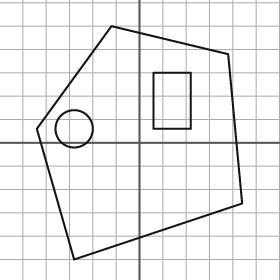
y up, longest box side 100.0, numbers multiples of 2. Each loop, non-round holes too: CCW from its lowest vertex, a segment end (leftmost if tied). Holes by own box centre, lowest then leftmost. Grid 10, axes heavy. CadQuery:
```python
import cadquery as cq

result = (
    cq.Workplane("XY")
    .moveTo(-28.0, -50.0)
    .lineTo(44.0, -26.0)
    .lineTo(38.0, 38.0)
    .lineTo(-12.0, 50.0)
    .lineTo(-44.0, 6.0)
    .close()
    .moveTo(-28.0, 6.0)
    .circle(8.0)
    .moveTo(6.0, 6.0)
    .lineTo(22.0, 6.0)
    .lineTo(22.0, 30.0)
    .lineTo(6.0, 30.0)
    .close()
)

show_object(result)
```